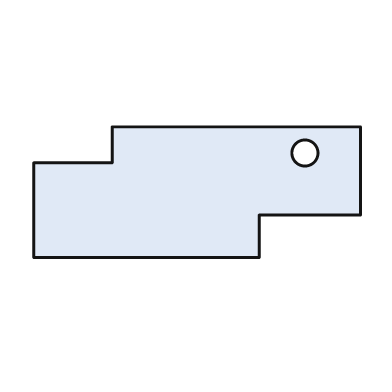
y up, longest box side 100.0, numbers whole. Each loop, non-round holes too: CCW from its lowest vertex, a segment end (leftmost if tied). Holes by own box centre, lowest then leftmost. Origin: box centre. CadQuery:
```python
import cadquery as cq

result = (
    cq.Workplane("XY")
    .moveTo(-50.0, -20.0)
    .lineTo(19.0, -20.0)
    .lineTo(19.0, -7.0)
    .lineTo(50.0, -7.0)
    .lineTo(50.0, 20.0)
    .lineTo(-26.0, 20.0)
    .lineTo(-26.0, 9.0)
    .lineTo(-50.0, 9.0)
    .close()
    .moveTo(33.0, 12.0)
    .circle(4.0)
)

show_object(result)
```